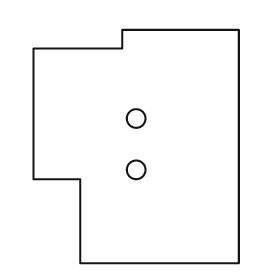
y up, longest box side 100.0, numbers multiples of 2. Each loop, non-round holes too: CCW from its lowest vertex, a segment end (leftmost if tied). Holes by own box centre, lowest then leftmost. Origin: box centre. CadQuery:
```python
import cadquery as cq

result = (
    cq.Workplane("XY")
    .moveTo(-24.0, -50.0)
    .lineTo(44.0, -50.0)
    .lineTo(44.0, 50.0)
    .lineTo(-6.0, 50.0)
    .lineTo(-6.0, 42.0)
    .lineTo(-44.0, 42.0)
    .lineTo(-44.0, -14.0)
    .lineTo(-24.0, -14.0)
    .close()
    .moveTo(0.0, -10.0)
    .circle(4.0)
    .moveTo(0.0, 12.0)
    .circle(4.0)
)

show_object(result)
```